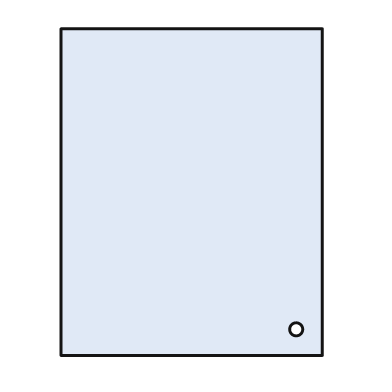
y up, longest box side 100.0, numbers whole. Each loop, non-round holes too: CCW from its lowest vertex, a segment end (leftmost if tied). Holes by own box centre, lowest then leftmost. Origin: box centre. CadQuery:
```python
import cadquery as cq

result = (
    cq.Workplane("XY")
    .moveTo(-40.0, -50.0)
    .lineTo(40.0, -50.0)
    .lineTo(40.0, 50.0)
    .lineTo(-40.0, 50.0)
    .close()
    .moveTo(32.0, -42.0)
    .circle(2.0)
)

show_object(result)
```